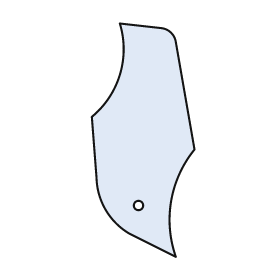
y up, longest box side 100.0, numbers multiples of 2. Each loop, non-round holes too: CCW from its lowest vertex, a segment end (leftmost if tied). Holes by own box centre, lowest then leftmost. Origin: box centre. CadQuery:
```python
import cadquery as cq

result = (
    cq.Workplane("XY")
    .moveTo(14.0, -50.0)
    .threePointArc((12.0, -26.0), (22.0, -4.0))
    .lineTo(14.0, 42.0)
    .threePointArc((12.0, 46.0), (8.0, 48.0))
    .lineTo(-10.0, 50.0)
    .threePointArc((-10.0, 28.0), (-22.0, 10.0))
    .lineTo(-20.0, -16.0)
    .threePointArc((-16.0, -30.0), (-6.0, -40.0))
    .close()
    .moveTo(-2.0, -28.0)
    .circle(2.0)
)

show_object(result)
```